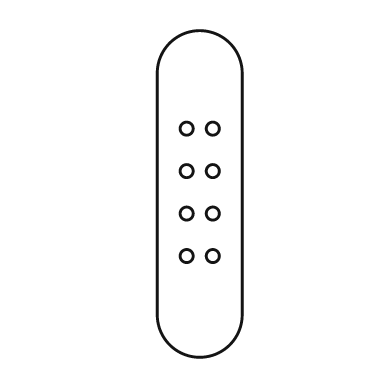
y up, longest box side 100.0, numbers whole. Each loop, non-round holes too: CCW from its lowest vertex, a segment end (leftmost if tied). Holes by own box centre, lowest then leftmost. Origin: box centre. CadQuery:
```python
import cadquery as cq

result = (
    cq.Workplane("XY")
    .moveTo(-13.0, -37.0)
    .threePointArc((0.0, -50.0), (13.0, -37.0))
    .lineTo(13.0, 37.0)
    .threePointArc((0.0, 50.0), (-13.0, 37.0))
    .close()
    .moveTo(-4.0, -19.0)
    .circle(2.0)
    .moveTo(4.0, -19.0)
    .circle(2.0)
    .moveTo(-4.0, -6.0)
    .circle(2.0)
    .moveTo(4.0, -6.0)
    .circle(2.0)
    .moveTo(-4.0, 7.0)
    .circle(2.0)
    .moveTo(4.0, 7.0)
    .circle(2.0)
    .moveTo(-4.0, 20.0)
    .circle(2.0)
    .moveTo(4.0, 20.0)
    .circle(2.0)
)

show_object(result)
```